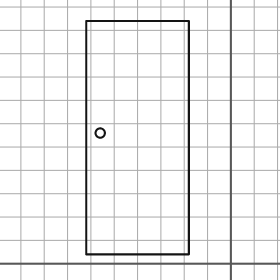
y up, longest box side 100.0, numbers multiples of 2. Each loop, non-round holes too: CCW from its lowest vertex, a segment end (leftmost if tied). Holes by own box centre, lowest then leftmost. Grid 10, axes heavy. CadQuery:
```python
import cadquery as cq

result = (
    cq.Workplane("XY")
    .moveTo(-62.0, 4.0)
    .lineTo(-18.0, 4.0)
    .lineTo(-18.0, 104.0)
    .lineTo(-62.0, 104.0)
    .close()
    .moveTo(-56.0, 56.0)
    .circle(2.0)
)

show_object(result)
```